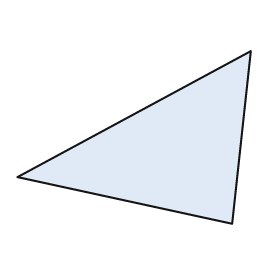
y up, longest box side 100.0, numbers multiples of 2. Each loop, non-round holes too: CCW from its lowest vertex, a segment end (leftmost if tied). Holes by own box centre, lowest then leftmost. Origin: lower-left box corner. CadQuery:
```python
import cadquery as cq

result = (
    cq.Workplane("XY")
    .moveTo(92.0, 0.0)
    .lineTo(100.0, 74.0)
    .lineTo(0.0, 20.0)
    .close()
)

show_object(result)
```